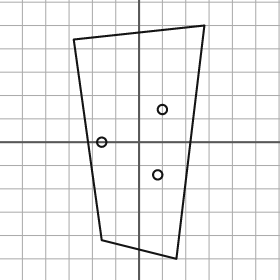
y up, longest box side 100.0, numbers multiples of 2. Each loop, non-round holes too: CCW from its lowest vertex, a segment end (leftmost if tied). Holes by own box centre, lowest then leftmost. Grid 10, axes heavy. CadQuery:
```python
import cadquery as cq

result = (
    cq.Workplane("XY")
    .moveTo(16.0, -50.0)
    .lineTo(28.0, 50.0)
    .lineTo(-28.0, 44.0)
    .lineTo(-16.0, -42.0)
    .close()
    .moveTo(8.0, -14.0)
    .circle(2.0)
    .moveTo(-16.0, 0.0)
    .circle(2.0)
    .moveTo(10.0, 14.0)
    .circle(2.0)
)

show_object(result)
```